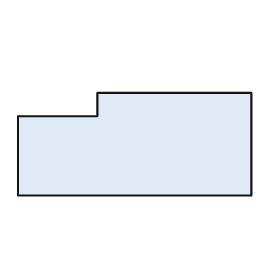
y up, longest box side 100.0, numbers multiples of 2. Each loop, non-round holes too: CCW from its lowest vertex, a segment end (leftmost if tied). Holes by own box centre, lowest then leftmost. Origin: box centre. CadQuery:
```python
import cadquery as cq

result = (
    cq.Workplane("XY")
    .moveTo(-50.0, -22.0)
    .lineTo(50.0, -22.0)
    .lineTo(50.0, 22.0)
    .lineTo(-16.0, 22.0)
    .lineTo(-16.0, 12.0)
    .lineTo(-50.0, 12.0)
    .close()
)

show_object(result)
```